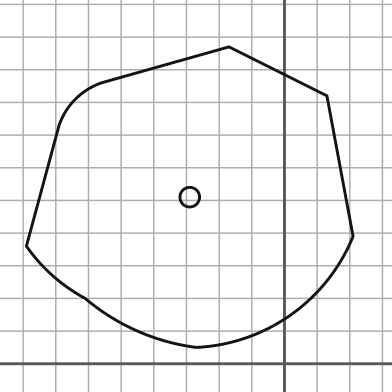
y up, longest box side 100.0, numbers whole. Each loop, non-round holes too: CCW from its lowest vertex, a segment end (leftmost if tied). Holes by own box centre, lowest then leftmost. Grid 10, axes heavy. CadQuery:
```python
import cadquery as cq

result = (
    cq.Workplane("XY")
    .moveTo(-27.0, 5.0)
    .threePointArc((2.0, 15.0), (21.0, 39.0))
    .lineTo(13.0, 82.0)
    .lineTo(-17.0, 97.0)
    .lineTo(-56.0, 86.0)
    .threePointArc((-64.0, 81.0), (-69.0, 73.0))
    .lineTo(-79.0, 36.0)
    .threePointArc((-71.0, 27.0), (-61.0, 20.0))
    .threePointArc((-45.0, 10.0), (-27.0, 5.0))
    .close()
    .moveTo(-29.0, 51.0)
    .circle(3.0)
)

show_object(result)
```